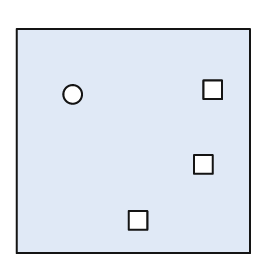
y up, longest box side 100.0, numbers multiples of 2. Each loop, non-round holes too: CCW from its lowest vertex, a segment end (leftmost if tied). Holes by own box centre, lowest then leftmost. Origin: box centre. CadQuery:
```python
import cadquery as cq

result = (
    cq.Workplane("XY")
    .moveTo(-50.0, -48.0)
    .lineTo(50.0, -48.0)
    .lineTo(50.0, 48.0)
    .lineTo(-50.0, 48.0)
    .close()
    .moveTo(-2.0, -38.0)
    .lineTo(6.0, -38.0)
    .lineTo(6.0, -30.0)
    .lineTo(-2.0, -30.0)
    .close()
    .moveTo(26.0, -14.0)
    .lineTo(34.0, -14.0)
    .lineTo(34.0, -6.0)
    .lineTo(26.0, -6.0)
    .close()
    .moveTo(-26.0, 20.0)
    .circle(4.0)
    .moveTo(30.0, 18.0)
    .lineTo(38.0, 18.0)
    .lineTo(38.0, 26.0)
    .lineTo(30.0, 26.0)
    .close()
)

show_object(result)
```